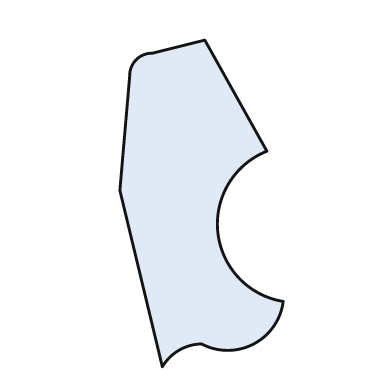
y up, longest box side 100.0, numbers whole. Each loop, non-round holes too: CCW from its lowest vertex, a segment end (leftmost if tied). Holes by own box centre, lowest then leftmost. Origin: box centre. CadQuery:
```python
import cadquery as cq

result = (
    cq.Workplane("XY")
    .moveTo(-12.0, -50.0)
    .threePointArc((-7.0, -45.0), (0.0, -43.0))
    .threePointArc((16.0, -43.0), (25.0, -30.0))
    .threePointArc((5.0, -9.0), (20.0, 16.0))
    .lineTo(1.0, 50.0)
    .lineTo(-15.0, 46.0)
    .threePointArc((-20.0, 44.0), (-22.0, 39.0))
    .lineTo(-25.0, 4.0)
    .close()
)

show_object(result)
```